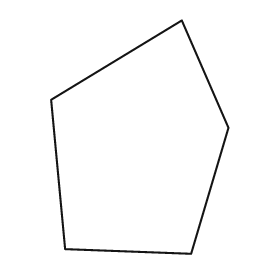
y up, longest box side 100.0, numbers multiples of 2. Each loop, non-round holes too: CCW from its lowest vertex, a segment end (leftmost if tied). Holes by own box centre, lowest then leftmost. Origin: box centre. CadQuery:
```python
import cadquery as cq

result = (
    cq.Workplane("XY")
    .moveTo(22.0, -50.0)
    .lineTo(38.0, 4.0)
    .lineTo(18.0, 50.0)
    .lineTo(-38.0, 16.0)
    .lineTo(-32.0, -48.0)
    .close()
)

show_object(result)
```